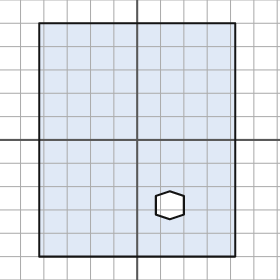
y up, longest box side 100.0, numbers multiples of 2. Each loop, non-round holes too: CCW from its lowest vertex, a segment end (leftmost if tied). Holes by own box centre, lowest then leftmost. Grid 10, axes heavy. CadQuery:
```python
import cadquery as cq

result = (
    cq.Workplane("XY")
    .moveTo(-42.0, -50.0)
    .lineTo(42.0, -50.0)
    .lineTo(42.0, 50.0)
    .lineTo(-42.0, 50.0)
    .close()
    .moveTo(14.0, -34.0)
    .lineTo(20.0, -32.0)
    .lineTo(20.0, -24.0)
    .lineTo(14.0, -22.0)
    .lineTo(8.0, -24.0)
    .lineTo(8.0, -32.0)
    .close()
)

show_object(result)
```